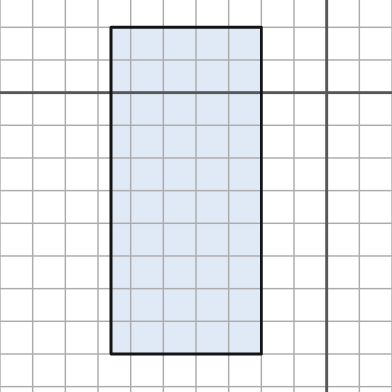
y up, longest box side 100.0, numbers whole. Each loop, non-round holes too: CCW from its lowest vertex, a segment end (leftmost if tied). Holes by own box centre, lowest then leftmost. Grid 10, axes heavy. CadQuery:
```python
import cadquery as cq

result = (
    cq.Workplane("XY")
    .moveTo(-66.0, -80.0)
    .lineTo(-20.0, -80.0)
    .lineTo(-20.0, 20.0)
    .lineTo(-66.0, 20.0)
    .close()
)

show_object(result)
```